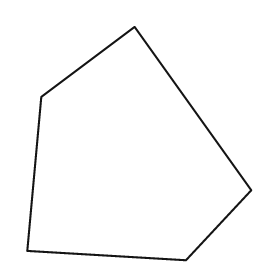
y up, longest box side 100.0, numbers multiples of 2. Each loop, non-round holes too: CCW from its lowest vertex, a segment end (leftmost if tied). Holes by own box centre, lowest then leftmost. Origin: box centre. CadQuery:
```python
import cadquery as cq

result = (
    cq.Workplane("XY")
    .moveTo(20.0, -50.0)
    .lineTo(48.0, -20.0)
    .lineTo(-2.0, 50.0)
    .lineTo(-42.0, 20.0)
    .lineTo(-48.0, -46.0)
    .close()
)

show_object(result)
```